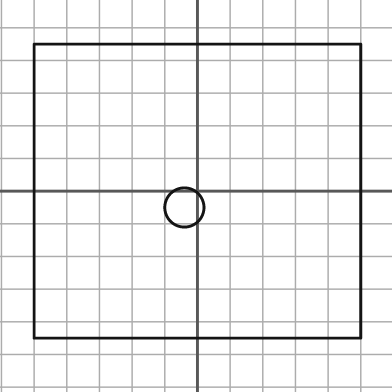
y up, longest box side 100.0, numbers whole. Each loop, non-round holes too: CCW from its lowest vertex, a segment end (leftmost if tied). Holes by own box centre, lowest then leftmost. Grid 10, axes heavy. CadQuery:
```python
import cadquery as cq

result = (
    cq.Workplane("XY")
    .moveTo(-50.0, -45.0)
    .lineTo(50.0, -45.0)
    .lineTo(50.0, 45.0)
    .lineTo(-50.0, 45.0)
    .close()
    .moveTo(-4.0, -5.0)
    .circle(6.0)
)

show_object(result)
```